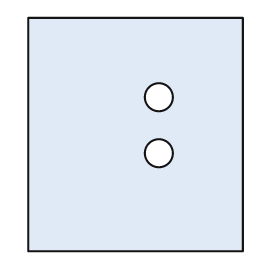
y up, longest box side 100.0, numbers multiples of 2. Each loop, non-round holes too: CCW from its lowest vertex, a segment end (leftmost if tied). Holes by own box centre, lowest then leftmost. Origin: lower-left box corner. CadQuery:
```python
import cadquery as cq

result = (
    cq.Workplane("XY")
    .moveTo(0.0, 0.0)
    .lineTo(92.0, 0.0)
    .lineTo(92.0, 100.0)
    .lineTo(0.0, 100.0)
    .close()
    .moveTo(56.0, 42.0)
    .circle(6.0)
    .moveTo(56.0, 66.0)
    .circle(6.0)
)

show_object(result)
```